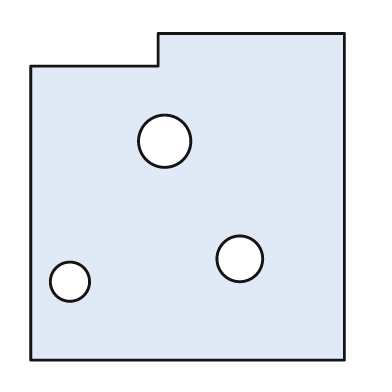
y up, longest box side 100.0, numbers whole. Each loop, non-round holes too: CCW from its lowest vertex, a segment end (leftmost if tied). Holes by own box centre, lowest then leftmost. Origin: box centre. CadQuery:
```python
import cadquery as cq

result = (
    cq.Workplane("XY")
    .moveTo(-48.0, -50.0)
    .lineTo(48.0, -50.0)
    .lineTo(48.0, 50.0)
    .lineTo(-9.0, 50.0)
    .lineTo(-9.0, 40.0)
    .lineTo(-48.0, 40.0)
    .close()
    .moveTo(-36.0, -26.0)
    .circle(6.0)
    .moveTo(16.0, -19.0)
    .circle(7.0)
    .moveTo(-7.0, 17.0)
    .circle(8.0)
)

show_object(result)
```